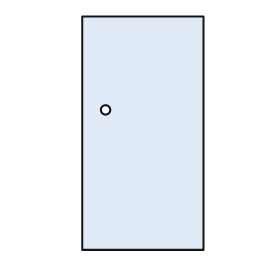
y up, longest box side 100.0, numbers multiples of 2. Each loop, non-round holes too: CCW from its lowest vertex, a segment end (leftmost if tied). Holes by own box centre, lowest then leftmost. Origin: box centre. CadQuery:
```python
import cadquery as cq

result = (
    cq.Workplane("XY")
    .moveTo(-26.0, -50.0)
    .lineTo(26.0, -50.0)
    .lineTo(26.0, 50.0)
    .lineTo(-26.0, 50.0)
    .close()
    .moveTo(-16.0, 10.0)
    .circle(2.0)
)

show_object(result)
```